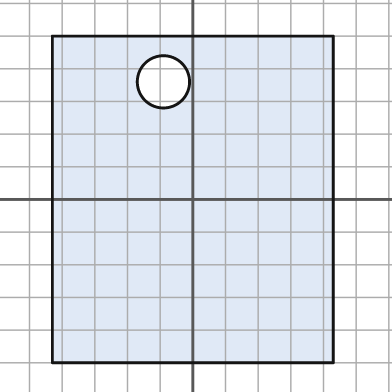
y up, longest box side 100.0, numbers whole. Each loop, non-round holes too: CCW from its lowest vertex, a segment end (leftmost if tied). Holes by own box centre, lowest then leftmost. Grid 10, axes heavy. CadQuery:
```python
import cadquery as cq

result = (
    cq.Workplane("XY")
    .moveTo(-43.0, -50.0)
    .lineTo(43.0, -50.0)
    .lineTo(43.0, 50.0)
    .lineTo(-43.0, 50.0)
    .close()
    .moveTo(-9.0, 36.0)
    .circle(8.0)
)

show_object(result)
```